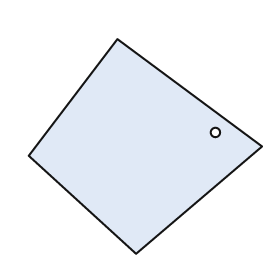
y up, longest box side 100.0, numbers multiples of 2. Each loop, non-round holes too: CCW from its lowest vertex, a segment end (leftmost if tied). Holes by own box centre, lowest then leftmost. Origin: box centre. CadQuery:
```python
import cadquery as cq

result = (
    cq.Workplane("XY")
    .moveTo(-4.0, -46.0)
    .lineTo(50.0, 0.0)
    .lineTo(-12.0, 46.0)
    .lineTo(-50.0, -4.0)
    .close()
    .moveTo(30.0, 6.0)
    .circle(2.0)
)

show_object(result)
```